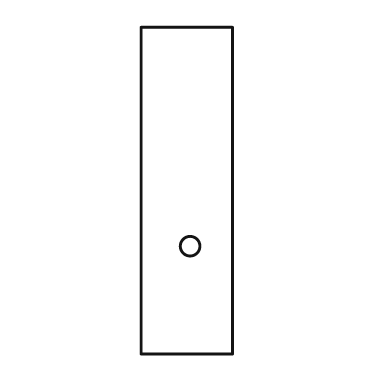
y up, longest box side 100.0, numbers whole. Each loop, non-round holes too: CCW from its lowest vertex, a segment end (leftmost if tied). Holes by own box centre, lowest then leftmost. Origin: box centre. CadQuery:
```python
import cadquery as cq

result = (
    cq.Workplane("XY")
    .moveTo(-14.0, -50.0)
    .lineTo(14.0, -50.0)
    .lineTo(14.0, 50.0)
    .lineTo(-14.0, 50.0)
    .close()
    .moveTo(1.0, -17.0)
    .circle(3.0)
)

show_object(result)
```